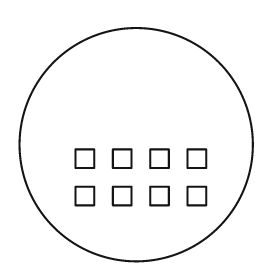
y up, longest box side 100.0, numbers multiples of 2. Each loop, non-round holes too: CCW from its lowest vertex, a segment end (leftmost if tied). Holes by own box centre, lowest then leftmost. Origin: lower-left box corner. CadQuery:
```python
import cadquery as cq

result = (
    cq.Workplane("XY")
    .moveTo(50.0, 50.0)
    .circle(50.0)
    .moveTo(24.0, 24.0)
    .lineTo(32.0, 24.0)
    .lineTo(32.0, 32.0)
    .lineTo(24.0, 32.0)
    .close()
    .moveTo(40.0, 24.0)
    .lineTo(48.0, 24.0)
    .lineTo(48.0, 32.0)
    .lineTo(40.0, 32.0)
    .close()
    .moveTo(56.0, 24.0)
    .lineTo(64.0, 24.0)
    .lineTo(64.0, 32.0)
    .lineTo(56.0, 32.0)
    .close()
    .moveTo(72.0, 24.0)
    .lineTo(80.0, 24.0)
    .lineTo(80.0, 32.0)
    .lineTo(72.0, 32.0)
    .close()
    .moveTo(24.0, 40.0)
    .lineTo(32.0, 40.0)
    .lineTo(32.0, 48.0)
    .lineTo(24.0, 48.0)
    .close()
    .moveTo(40.0, 40.0)
    .lineTo(48.0, 40.0)
    .lineTo(48.0, 48.0)
    .lineTo(40.0, 48.0)
    .close()
    .moveTo(56.0, 40.0)
    .lineTo(64.0, 40.0)
    .lineTo(64.0, 48.0)
    .lineTo(56.0, 48.0)
    .close()
    .moveTo(72.0, 40.0)
    .lineTo(80.0, 40.0)
    .lineTo(80.0, 48.0)
    .lineTo(72.0, 48.0)
    .close()
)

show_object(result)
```